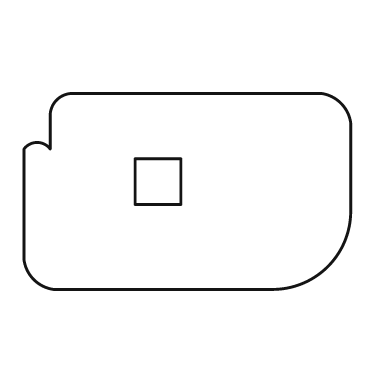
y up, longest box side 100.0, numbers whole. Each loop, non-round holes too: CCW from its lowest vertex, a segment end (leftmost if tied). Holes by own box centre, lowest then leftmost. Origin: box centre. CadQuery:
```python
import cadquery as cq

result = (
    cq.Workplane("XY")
    .moveTo(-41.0, -30.0)
    .lineTo(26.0, -30.0)
    .threePointArc((43.0, -23.0), (50.0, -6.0))
    .lineTo(50.0, 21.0)
    .threePointArc((47.0, 27.0), (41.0, 30.0))
    .lineTo(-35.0, 30.0)
    .threePointArc((-40.0, 28.0), (-42.0, 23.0))
    .lineTo(-42.0, 13.0)
    .threePointArc((-46.0, 15.0), (-50.0, 13.0))
    .lineTo(-50.0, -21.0)
    .threePointArc((-47.0, -27.0), (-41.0, -30.0))
    .close()
    .moveTo(-16.0, -4.0)
    .lineTo(-2.0, -4.0)
    .lineTo(-2.0, 10.0)
    .lineTo(-16.0, 10.0)
    .close()
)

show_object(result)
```